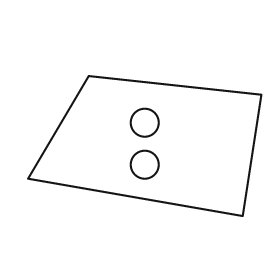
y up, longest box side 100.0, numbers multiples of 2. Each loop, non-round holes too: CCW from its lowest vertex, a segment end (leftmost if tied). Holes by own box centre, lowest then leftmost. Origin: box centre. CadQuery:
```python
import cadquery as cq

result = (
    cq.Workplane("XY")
    .moveTo(42.0, -30.0)
    .lineTo(50.0, 22.0)
    .lineTo(-24.0, 30.0)
    .lineTo(-50.0, -14.0)
    .close()
    .moveTo(0.0, -8.0)
    .circle(6.0)
    .moveTo(0.0, 10.0)
    .circle(6.0)
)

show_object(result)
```